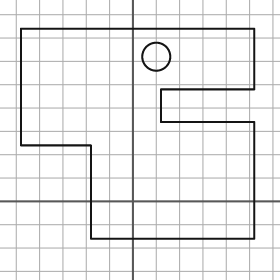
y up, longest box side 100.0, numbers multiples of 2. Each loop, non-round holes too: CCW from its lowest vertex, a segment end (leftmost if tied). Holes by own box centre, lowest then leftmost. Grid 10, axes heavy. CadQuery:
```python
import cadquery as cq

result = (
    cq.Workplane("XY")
    .moveTo(-18.0, -16.0)
    .lineTo(52.0, -16.0)
    .lineTo(52.0, 34.0)
    .lineTo(12.0, 34.0)
    .lineTo(12.0, 48.0)
    .lineTo(52.0, 48.0)
    .lineTo(52.0, 74.0)
    .lineTo(-48.0, 74.0)
    .lineTo(-48.0, 24.0)
    .lineTo(-18.0, 24.0)
    .close()
    .moveTo(10.0, 62.0)
    .circle(6.0)
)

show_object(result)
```